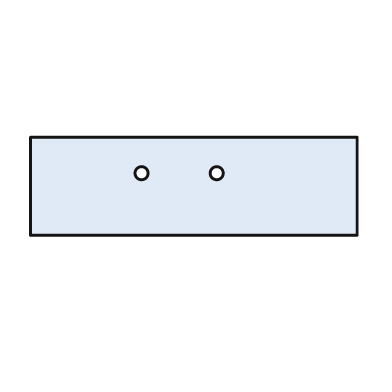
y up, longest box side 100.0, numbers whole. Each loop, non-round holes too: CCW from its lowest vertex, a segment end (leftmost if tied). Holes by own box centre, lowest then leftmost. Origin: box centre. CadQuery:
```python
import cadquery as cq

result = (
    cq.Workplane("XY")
    .moveTo(-50.0, -15.0)
    .lineTo(50.0, -15.0)
    .lineTo(50.0, 15.0)
    .lineTo(-50.0, 15.0)
    .close()
    .moveTo(-16.0, 4.0)
    .circle(2.0)
    .moveTo(7.0, 4.0)
    .circle(2.0)
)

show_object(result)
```